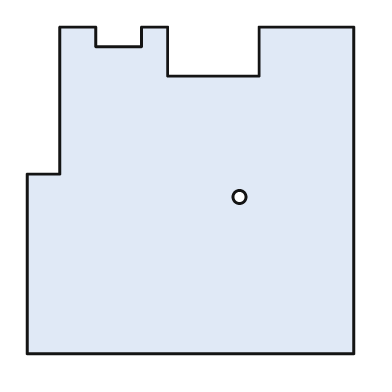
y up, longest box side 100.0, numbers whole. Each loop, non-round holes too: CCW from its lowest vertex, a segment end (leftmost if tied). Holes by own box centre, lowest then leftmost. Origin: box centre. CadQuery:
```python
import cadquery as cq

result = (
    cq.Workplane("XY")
    .moveTo(-50.0, -50.0)
    .lineTo(50.0, -50.0)
    .lineTo(50.0, 50.0)
    .lineTo(21.0, 50.0)
    .lineTo(21.0, 35.0)
    .lineTo(-7.0, 35.0)
    .lineTo(-7.0, 50.0)
    .lineTo(-15.0, 50.0)
    .lineTo(-15.0, 44.0)
    .lineTo(-29.0, 44.0)
    .lineTo(-29.0, 50.0)
    .lineTo(-40.0, 50.0)
    .lineTo(-40.0, 5.0)
    .lineTo(-50.0, 5.0)
    .close()
    .moveTo(15.0, -2.0)
    .circle(2.0)
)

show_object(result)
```